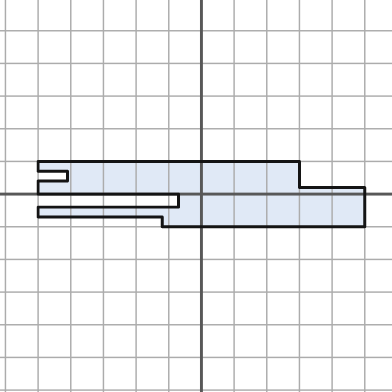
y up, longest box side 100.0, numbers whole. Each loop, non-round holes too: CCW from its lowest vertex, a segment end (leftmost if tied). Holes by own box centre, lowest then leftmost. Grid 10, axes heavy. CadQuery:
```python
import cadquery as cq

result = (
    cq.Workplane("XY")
    .moveTo(-12.0, -10.0)
    .lineTo(50.0, -10.0)
    .lineTo(50.0, 2.0)
    .lineTo(30.0, 2.0)
    .lineTo(30.0, 10.0)
    .lineTo(-50.0, 10.0)
    .lineTo(-50.0, 7.0)
    .lineTo(-41.0, 7.0)
    .lineTo(-41.0, 4.0)
    .lineTo(-50.0, 4.0)
    .lineTo(-50.0, 0.0)
    .lineTo(-7.0, 0.0)
    .lineTo(-7.0, -4.0)
    .lineTo(-50.0, -4.0)
    .lineTo(-50.0, -7.0)
    .lineTo(-12.0, -7.0)
    .close()
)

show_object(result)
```